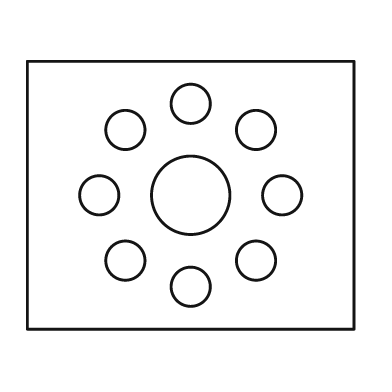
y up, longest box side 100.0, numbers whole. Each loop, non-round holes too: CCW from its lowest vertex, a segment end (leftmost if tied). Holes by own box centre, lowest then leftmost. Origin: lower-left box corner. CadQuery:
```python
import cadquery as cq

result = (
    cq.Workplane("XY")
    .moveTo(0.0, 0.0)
    .lineTo(100.0, 0.0)
    .lineTo(100.0, 82.0)
    .lineTo(0.0, 82.0)
    .close()
    .moveTo(50.0, 13.0)
    .circle(6.0)
    .moveTo(30.0, 21.0)
    .circle(6.0)
    .moveTo(70.0, 21.0)
    .circle(6.0)
    .moveTo(22.0, 41.0)
    .circle(6.0)
    .moveTo(50.0, 41.0)
    .circle(12.0)
    .moveTo(78.0, 41.0)
    .circle(6.0)
    .moveTo(30.0, 61.0)
    .circle(6.0)
    .moveTo(70.0, 61.0)
    .circle(6.0)
    .moveTo(50.0, 69.0)
    .circle(6.0)
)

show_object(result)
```